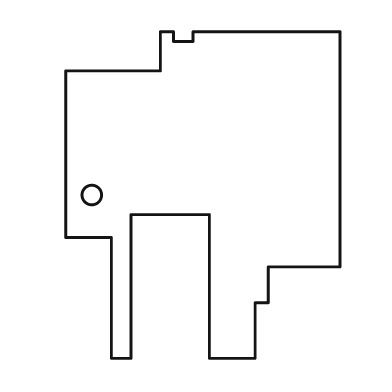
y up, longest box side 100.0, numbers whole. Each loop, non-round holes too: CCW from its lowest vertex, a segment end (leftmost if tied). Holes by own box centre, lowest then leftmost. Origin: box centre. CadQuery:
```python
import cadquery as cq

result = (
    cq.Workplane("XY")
    .moveTo(-28.0, -50.0)
    .lineTo(-22.0, -50.0)
    .lineTo(-22.0, -6.0)
    .lineTo(2.0, -6.0)
    .lineTo(2.0, -50.0)
    .lineTo(16.0, -50.0)
    .lineTo(16.0, -33.0)
    .lineTo(20.0, -33.0)
    .lineTo(20.0, -22.0)
    .lineTo(42.0, -22.0)
    .lineTo(42.0, 50.0)
    .lineTo(-3.0, 50.0)
    .lineTo(-3.0, 47.0)
    .lineTo(-9.0, 47.0)
    .lineTo(-9.0, 50.0)
    .lineTo(-13.0, 50.0)
    .lineTo(-13.0, 38.0)
    .lineTo(-42.0, 38.0)
    .lineTo(-42.0, -13.0)
    .lineTo(-28.0, -13.0)
    .close()
    .moveTo(-34.0, 0.0)
    .circle(3.0)
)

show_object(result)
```